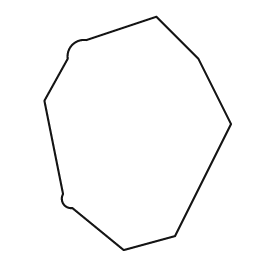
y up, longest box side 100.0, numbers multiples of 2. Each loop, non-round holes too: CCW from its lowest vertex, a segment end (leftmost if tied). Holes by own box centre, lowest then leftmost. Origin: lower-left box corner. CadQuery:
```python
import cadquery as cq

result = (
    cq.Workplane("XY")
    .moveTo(34.0, 0.0)
    .lineTo(56.0, 6.0)
    .lineTo(80.0, 54.0)
    .lineTo(66.0, 82.0)
    .lineTo(48.0, 100.0)
    .lineTo(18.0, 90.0)
    .threePointArc((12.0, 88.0), (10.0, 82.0))
    .lineTo(0.0, 64.0)
    .lineTo(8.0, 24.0)
    .threePointArc((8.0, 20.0), (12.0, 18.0))
    .close()
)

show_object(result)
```